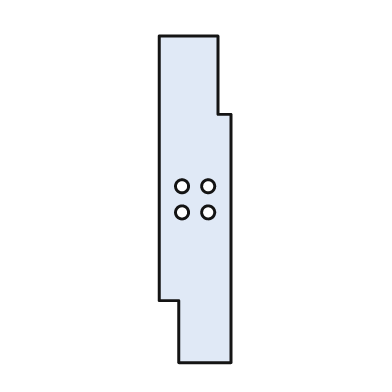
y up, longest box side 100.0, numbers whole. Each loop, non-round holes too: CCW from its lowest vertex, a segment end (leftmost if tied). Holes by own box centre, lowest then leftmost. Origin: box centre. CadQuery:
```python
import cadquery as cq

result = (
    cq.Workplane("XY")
    .moveTo(-5.0, -50.0)
    .lineTo(11.0, -50.0)
    .lineTo(11.0, 26.0)
    .lineTo(7.0, 26.0)
    .lineTo(7.0, 50.0)
    .lineTo(-11.0, 50.0)
    .lineTo(-11.0, -31.0)
    .lineTo(-5.0, -31.0)
    .close()
    .moveTo(-4.0, -4.0)
    .circle(2.0)
    .moveTo(4.0, -4.0)
    .circle(2.0)
    .moveTo(-4.0, 4.0)
    .circle(2.0)
    .moveTo(4.0, 4.0)
    .circle(2.0)
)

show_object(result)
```